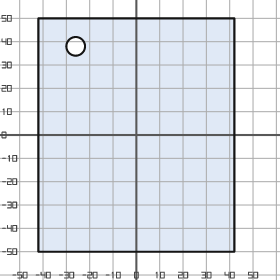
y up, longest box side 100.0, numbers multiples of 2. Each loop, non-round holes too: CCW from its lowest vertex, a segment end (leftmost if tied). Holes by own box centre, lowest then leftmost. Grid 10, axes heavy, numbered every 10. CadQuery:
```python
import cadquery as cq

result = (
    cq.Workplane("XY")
    .moveTo(-42.0, -50.0)
    .lineTo(42.0, -50.0)
    .lineTo(42.0, 50.0)
    .lineTo(-42.0, 50.0)
    .close()
    .moveTo(-26.0, 38.0)
    .circle(4.0)
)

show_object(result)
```